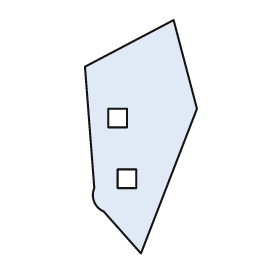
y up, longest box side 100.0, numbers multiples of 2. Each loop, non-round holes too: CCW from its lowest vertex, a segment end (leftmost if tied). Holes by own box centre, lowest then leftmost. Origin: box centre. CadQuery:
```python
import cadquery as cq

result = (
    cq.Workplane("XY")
    .moveTo(0.0, -50.0)
    .lineTo(24.0, 12.0)
    .lineTo(14.0, 50.0)
    .lineTo(-24.0, 30.0)
    .lineTo(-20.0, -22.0)
    .threePointArc((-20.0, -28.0), (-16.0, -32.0))
    .close()
    .moveTo(-10.0, -22.0)
    .lineTo(-2.0, -22.0)
    .lineTo(-2.0, -14.0)
    .lineTo(-10.0, -14.0)
    .close()
    .moveTo(-14.0, 4.0)
    .lineTo(-6.0, 4.0)
    .lineTo(-6.0, 12.0)
    .lineTo(-14.0, 12.0)
    .close()
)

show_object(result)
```